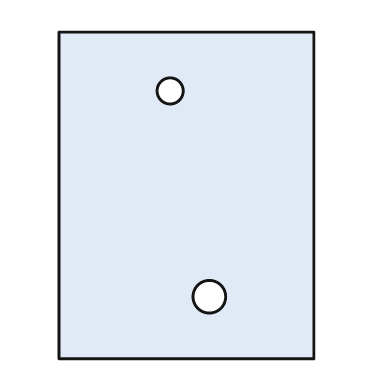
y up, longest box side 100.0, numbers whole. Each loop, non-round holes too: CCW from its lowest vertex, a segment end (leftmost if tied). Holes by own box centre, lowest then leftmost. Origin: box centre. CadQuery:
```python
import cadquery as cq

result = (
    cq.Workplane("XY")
    .moveTo(-39.0, -50.0)
    .lineTo(39.0, -50.0)
    .lineTo(39.0, 50.0)
    .lineTo(-39.0, 50.0)
    .close()
    .moveTo(7.0, -31.0)
    .circle(5.0)
    .moveTo(-5.0, 32.0)
    .circle(4.0)
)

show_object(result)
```